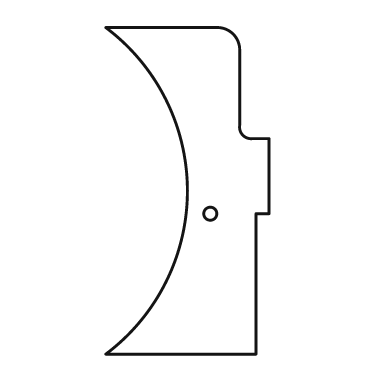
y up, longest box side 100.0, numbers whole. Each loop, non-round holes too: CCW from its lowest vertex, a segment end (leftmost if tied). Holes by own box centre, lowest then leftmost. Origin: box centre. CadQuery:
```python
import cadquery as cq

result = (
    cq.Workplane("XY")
    .moveTo(-25.0, -50.0)
    .lineTo(21.0, -50.0)
    .lineTo(21.0, -7.0)
    .lineTo(25.0, -7.0)
    .lineTo(25.0, 16.0)
    .lineTo(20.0, 16.0)
    .threePointArc((17.0, 17.0), (16.0, 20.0))
    .lineTo(16.0, 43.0)
    .threePointArc((14.0, 48.0), (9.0, 50.0))
    .lineTo(-25.0, 50.0)
    .threePointArc((0.0, 0.0), (-25.0, -50.0))
    .close()
    .moveTo(7.0, -7.0)
    .circle(2.0)
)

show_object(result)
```